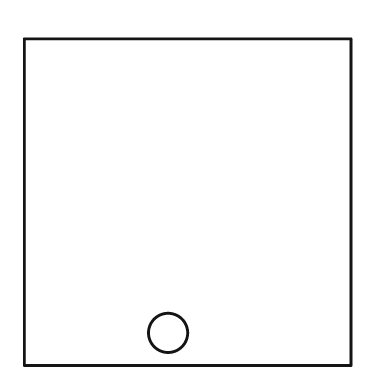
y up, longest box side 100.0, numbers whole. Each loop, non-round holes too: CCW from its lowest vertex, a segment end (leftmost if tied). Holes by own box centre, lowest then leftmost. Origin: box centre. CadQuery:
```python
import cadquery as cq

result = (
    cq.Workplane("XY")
    .moveTo(-50.0, -50.0)
    .lineTo(50.0, -50.0)
    .lineTo(50.0, 50.0)
    .lineTo(-50.0, 50.0)
    .close()
    .moveTo(-6.0, -40.0)
    .circle(6.0)
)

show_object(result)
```